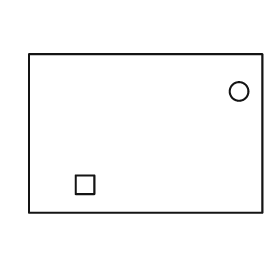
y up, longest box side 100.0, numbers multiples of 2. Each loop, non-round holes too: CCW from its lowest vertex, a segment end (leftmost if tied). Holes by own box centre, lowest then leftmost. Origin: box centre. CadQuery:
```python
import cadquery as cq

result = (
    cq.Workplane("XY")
    .moveTo(-50.0, -34.0)
    .lineTo(50.0, -34.0)
    .lineTo(50.0, 34.0)
    .lineTo(-50.0, 34.0)
    .close()
    .moveTo(-30.0, -26.0)
    .lineTo(-22.0, -26.0)
    .lineTo(-22.0, -18.0)
    .lineTo(-30.0, -18.0)
    .close()
    .moveTo(40.0, 18.0)
    .circle(4.0)
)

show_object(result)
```